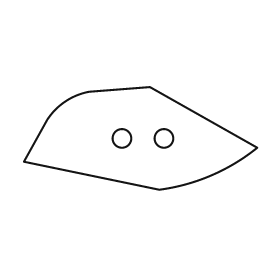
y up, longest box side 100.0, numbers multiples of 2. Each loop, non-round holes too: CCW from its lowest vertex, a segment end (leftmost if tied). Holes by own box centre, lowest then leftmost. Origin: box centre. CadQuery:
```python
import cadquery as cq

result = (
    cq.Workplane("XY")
    .moveTo(8.0, -22.0)
    .threePointArc((30.0, -16.0), (50.0, -4.0))
    .lineTo(4.0, 22.0)
    .lineTo(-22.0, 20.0)
    .threePointArc((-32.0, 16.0), (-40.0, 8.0))
    .lineTo(-50.0, -10.0)
    .close()
    .moveTo(-8.0, 0.0)
    .circle(4.0)
    .moveTo(10.0, 0.0)
    .circle(4.0)
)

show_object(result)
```